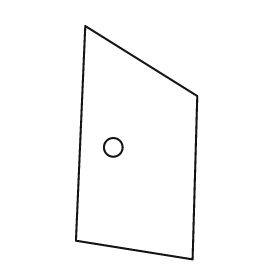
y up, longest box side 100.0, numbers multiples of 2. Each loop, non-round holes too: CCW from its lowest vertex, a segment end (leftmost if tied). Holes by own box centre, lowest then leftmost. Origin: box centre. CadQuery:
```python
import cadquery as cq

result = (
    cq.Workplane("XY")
    .moveTo(24.0, -50.0)
    .lineTo(26.0, 20.0)
    .lineTo(-22.0, 50.0)
    .lineTo(-26.0, -42.0)
    .close()
    .moveTo(-10.0, -2.0)
    .circle(4.0)
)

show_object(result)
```